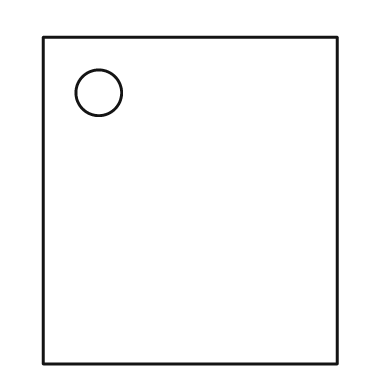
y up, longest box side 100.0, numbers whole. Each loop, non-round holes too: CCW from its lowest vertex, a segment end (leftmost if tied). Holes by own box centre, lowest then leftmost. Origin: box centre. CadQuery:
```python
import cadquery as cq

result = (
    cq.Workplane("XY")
    .moveTo(-45.0, -50.0)
    .lineTo(45.0, -50.0)
    .lineTo(45.0, 50.0)
    .lineTo(-45.0, 50.0)
    .close()
    .moveTo(-28.0, 33.0)
    .circle(7.0)
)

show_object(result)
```